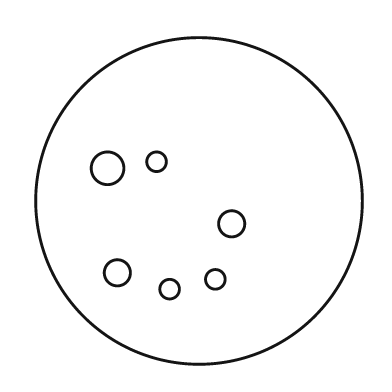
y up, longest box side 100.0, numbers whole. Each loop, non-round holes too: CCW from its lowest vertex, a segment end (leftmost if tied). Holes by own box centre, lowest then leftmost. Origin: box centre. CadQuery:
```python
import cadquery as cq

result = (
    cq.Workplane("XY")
    .moveTo(0.0, 0.0)
    .circle(50.0)
    .moveTo(-9.0, -27.0)
    .circle(3.0)
    .moveTo(5.0, -24.0)
    .circle(3.0)
    .moveTo(-25.0, -22.0)
    .circle(4.0)
    .moveTo(10.0, -7.0)
    .circle(4.0)
    .moveTo(-28.0, 10.0)
    .circle(5.0)
    .moveTo(-13.0, 12.0)
    .circle(3.0)
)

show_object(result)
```